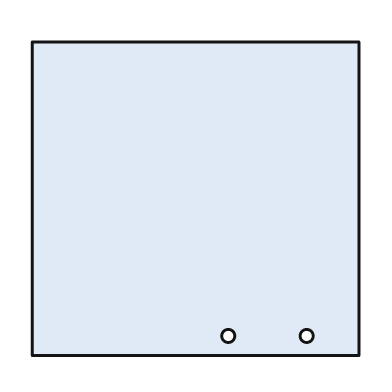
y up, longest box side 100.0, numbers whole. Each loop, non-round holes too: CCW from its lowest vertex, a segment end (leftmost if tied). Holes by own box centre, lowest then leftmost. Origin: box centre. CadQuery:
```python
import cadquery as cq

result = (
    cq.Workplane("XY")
    .moveTo(-50.0, -48.0)
    .lineTo(50.0, -48.0)
    .lineTo(50.0, 48.0)
    .lineTo(-50.0, 48.0)
    .close()
    .moveTo(10.0, -42.0)
    .circle(2.0)
    .moveTo(34.0, -42.0)
    .circle(2.0)
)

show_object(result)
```